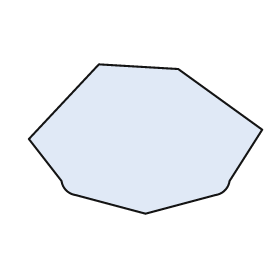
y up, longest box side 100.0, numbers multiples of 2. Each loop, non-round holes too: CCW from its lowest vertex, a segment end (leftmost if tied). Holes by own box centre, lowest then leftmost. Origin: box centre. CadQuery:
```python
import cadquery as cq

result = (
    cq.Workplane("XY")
    .moveTo(0.0, -32.0)
    .lineTo(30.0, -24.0)
    .threePointArc((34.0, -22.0), (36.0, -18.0))
    .lineTo(50.0, 4.0)
    .lineTo(14.0, 30.0)
    .lineTo(-20.0, 32.0)
    .lineTo(-50.0, 0.0)
    .lineTo(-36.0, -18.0)
    .threePointArc((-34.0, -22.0), (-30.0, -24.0))
    .close()
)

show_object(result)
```